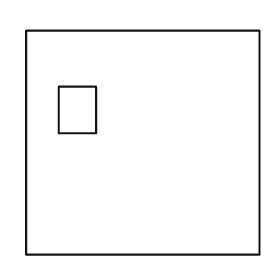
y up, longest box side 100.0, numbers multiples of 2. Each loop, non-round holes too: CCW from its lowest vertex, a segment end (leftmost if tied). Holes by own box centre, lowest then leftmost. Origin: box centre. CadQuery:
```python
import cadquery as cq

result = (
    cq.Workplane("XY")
    .moveTo(-50.0, -48.0)
    .lineTo(50.0, -48.0)
    .lineTo(50.0, 48.0)
    .lineTo(-50.0, 48.0)
    .close()
    .moveTo(-36.0, 4.0)
    .lineTo(-20.0, 4.0)
    .lineTo(-20.0, 24.0)
    .lineTo(-36.0, 24.0)
    .close()
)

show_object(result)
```